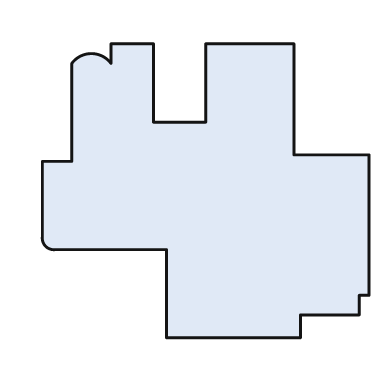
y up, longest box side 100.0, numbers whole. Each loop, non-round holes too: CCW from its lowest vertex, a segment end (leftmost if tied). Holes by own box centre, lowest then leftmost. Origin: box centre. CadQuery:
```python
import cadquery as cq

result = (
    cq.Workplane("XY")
    .moveTo(-12.0, -45.0)
    .lineTo(29.0, -45.0)
    .lineTo(29.0, -38.0)
    .lineTo(47.0, -38.0)
    .lineTo(47.0, -32.0)
    .lineTo(50.0, -32.0)
    .lineTo(50.0, 11.0)
    .lineTo(27.0, 11.0)
    .lineTo(27.0, 45.0)
    .lineTo(0.0, 45.0)
    .lineTo(0.0, 21.0)
    .lineTo(-16.0, 21.0)
    .lineTo(-16.0, 45.0)
    .lineTo(-29.0, 45.0)
    .lineTo(-29.0, 39.0)
    .threePointArc((-35.0, 42.0), (-41.0, 39.0))
    .lineTo(-41.0, 9.0)
    .lineTo(-50.0, 9.0)
    .lineTo(-50.0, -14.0)
    .threePointArc((-49.0, -17.0), (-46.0, -18.0))
    .lineTo(-12.0, -18.0)
    .close()
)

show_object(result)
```